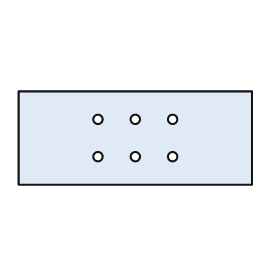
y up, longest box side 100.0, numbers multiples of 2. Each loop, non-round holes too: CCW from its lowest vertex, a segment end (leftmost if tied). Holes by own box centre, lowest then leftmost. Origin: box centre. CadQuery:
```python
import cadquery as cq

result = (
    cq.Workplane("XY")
    .moveTo(-50.0, -20.0)
    .lineTo(50.0, -20.0)
    .lineTo(50.0, 20.0)
    .lineTo(-50.0, 20.0)
    .close()
    .moveTo(-16.0, -8.0)
    .circle(2.0)
    .moveTo(0.0, -8.0)
    .circle(2.0)
    .moveTo(16.0, -8.0)
    .circle(2.0)
    .moveTo(-16.0, 8.0)
    .circle(2.0)
    .moveTo(0.0, 8.0)
    .circle(2.0)
    .moveTo(16.0, 8.0)
    .circle(2.0)
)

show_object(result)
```